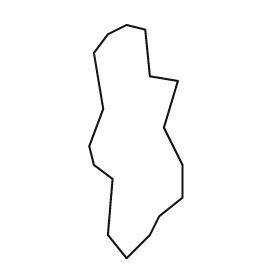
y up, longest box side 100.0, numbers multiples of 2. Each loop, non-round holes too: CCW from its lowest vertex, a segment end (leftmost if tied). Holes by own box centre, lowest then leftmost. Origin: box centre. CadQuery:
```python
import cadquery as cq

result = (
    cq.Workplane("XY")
    .moveTo(-4.0, -50.0)
    .lineTo(6.0, -40.0)
    .lineTo(10.0, -32.0)
    .lineTo(20.0, -24.0)
    .lineTo(20.0, -10.0)
    .lineTo(12.0, 6.0)
    .lineTo(18.0, 26.0)
    .lineTo(6.0, 28.0)
    .lineTo(4.0, 48.0)
    .lineTo(-4.0, 50.0)
    .lineTo(-12.0, 46.0)
    .lineTo(-18.0, 38.0)
    .lineTo(-14.0, 14.0)
    .lineTo(-20.0, -2.0)
    .lineTo(-18.0, -10.0)
    .lineTo(-10.0, -16.0)
    .lineTo(-12.0, -40.0)
    .close()
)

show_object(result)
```